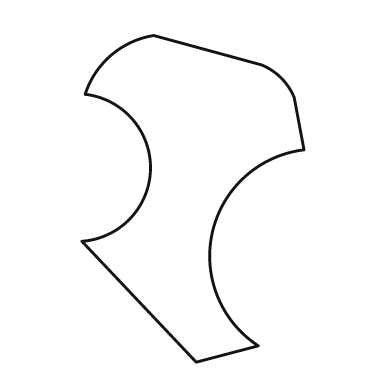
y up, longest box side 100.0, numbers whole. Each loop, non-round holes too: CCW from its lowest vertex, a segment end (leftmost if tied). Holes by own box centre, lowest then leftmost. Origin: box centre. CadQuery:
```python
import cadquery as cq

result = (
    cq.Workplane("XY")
    .moveTo(1.0, -50.0)
    .lineTo(20.0, -45.0)
    .threePointArc((6.0, -10.0), (34.0, 15.0))
    .lineTo(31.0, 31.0)
    .threePointArc((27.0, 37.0), (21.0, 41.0))
    .lineTo(-12.0, 50.0)
    .threePointArc((-25.0, 44.0), (-33.0, 32.0))
    .threePointArc((-13.0, 9.0), (-34.0, -13.0))
    .close()
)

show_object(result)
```